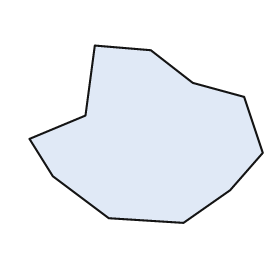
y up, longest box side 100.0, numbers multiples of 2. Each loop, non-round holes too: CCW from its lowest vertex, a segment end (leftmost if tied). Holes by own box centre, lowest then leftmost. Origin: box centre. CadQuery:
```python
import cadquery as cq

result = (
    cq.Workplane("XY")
    .moveTo(16.0, -38.0)
    .lineTo(36.0, -24.0)
    .lineTo(50.0, -8.0)
    .lineTo(42.0, 16.0)
    .lineTo(20.0, 22.0)
    .lineTo(2.0, 36.0)
    .lineTo(-22.0, 38.0)
    .lineTo(-26.0, 8.0)
    .lineTo(-50.0, -2.0)
    .lineTo(-40.0, -18.0)
    .lineTo(-16.0, -36.0)
    .close()
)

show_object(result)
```